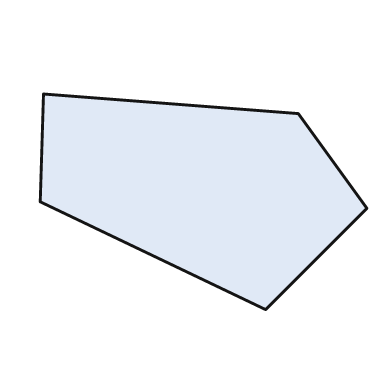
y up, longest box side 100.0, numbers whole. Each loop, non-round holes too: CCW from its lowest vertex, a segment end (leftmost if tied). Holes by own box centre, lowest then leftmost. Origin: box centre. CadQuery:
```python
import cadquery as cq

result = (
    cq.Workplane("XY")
    .moveTo(19.0, -33.0)
    .lineTo(50.0, -2.0)
    .lineTo(29.0, 27.0)
    .lineTo(-49.0, 33.0)
    .lineTo(-50.0, 0.0)
    .close()
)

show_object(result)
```